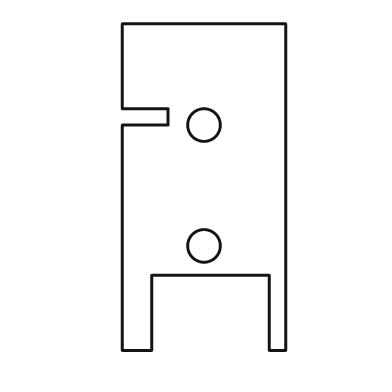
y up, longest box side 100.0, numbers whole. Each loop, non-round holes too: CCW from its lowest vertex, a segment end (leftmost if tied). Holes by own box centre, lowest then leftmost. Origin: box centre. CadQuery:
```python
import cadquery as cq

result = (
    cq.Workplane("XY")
    .moveTo(-25.0, -50.0)
    .lineTo(-16.0, -50.0)
    .lineTo(-16.0, -27.0)
    .lineTo(20.0, -27.0)
    .lineTo(20.0, -50.0)
    .lineTo(25.0, -50.0)
    .lineTo(25.0, 50.0)
    .lineTo(-25.0, 50.0)
    .lineTo(-25.0, 24.0)
    .lineTo(-11.0, 24.0)
    .lineTo(-11.0, 19.0)
    .lineTo(-25.0, 19.0)
    .close()
    .moveTo(0.0, -18.0)
    .circle(5.0)
    .moveTo(0.0, 19.0)
    .circle(5.0)
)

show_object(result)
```